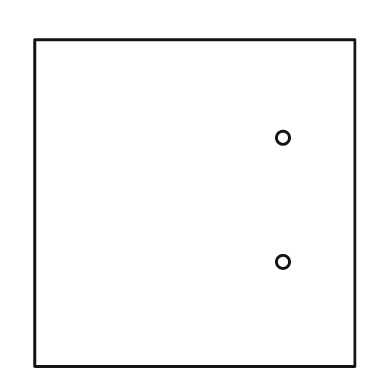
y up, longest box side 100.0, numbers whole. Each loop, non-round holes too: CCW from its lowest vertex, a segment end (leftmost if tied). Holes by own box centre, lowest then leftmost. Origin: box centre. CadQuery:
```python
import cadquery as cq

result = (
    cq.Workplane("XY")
    .moveTo(-49.0, -50.0)
    .lineTo(49.0, -50.0)
    .lineTo(49.0, 50.0)
    .lineTo(-49.0, 50.0)
    .close()
    .moveTo(27.0, -18.0)
    .circle(2.0)
    .moveTo(27.0, 20.0)
    .circle(2.0)
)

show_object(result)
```